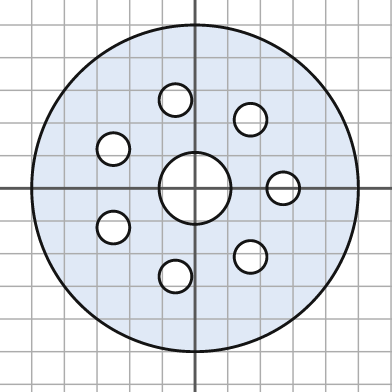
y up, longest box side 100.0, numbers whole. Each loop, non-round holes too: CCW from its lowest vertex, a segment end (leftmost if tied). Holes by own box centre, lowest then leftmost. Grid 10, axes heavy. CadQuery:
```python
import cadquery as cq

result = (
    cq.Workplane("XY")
    .moveTo(0.0, 0.0)
    .circle(50.0)
    .moveTo(-6.0, -27.0)
    .circle(5.0)
    .moveTo(17.0, -21.0)
    .circle(5.0)
    .moveTo(-25.0, -12.0)
    .circle(5.0)
    .moveTo(0.0, 0.0)
    .circle(11.0)
    .moveTo(27.0, 0.0)
    .circle(5.0)
    .moveTo(-25.0, 12.0)
    .circle(5.0)
    .moveTo(17.0, 21.0)
    .circle(5.0)
    .moveTo(-6.0, 27.0)
    .circle(5.0)
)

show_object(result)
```